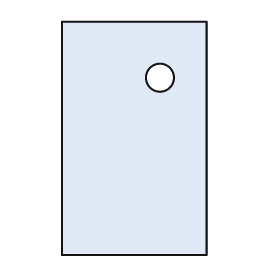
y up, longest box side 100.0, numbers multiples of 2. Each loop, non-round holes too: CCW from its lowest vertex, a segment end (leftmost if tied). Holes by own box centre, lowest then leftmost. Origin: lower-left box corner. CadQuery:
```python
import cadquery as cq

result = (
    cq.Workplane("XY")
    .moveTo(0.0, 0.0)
    .lineTo(62.0, 0.0)
    .lineTo(62.0, 100.0)
    .lineTo(0.0, 100.0)
    .close()
    .moveTo(42.0, 76.0)
    .circle(6.0)
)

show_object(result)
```